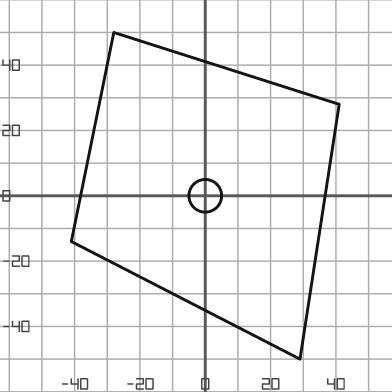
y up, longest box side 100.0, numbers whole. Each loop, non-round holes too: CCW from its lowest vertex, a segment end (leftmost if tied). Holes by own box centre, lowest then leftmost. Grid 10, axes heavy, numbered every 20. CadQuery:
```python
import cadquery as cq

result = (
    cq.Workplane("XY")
    .moveTo(29.0, -50.0)
    .lineTo(41.0, 28.0)
    .lineTo(-28.0, 50.0)
    .lineTo(-41.0, -14.0)
    .close()
    .moveTo(0.0, 0.0)
    .circle(5.0)
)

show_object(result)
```